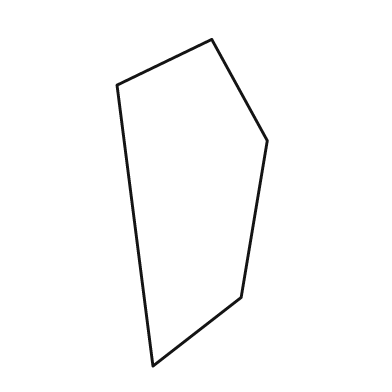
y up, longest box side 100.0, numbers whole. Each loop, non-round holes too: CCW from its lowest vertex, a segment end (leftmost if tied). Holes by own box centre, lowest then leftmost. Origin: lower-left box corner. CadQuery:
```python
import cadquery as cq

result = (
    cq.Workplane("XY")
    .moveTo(11.0, 0.0)
    .lineTo(38.0, 21.0)
    .lineTo(46.0, 69.0)
    .lineTo(29.0, 100.0)
    .lineTo(0.0, 86.0)
    .close()
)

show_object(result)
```